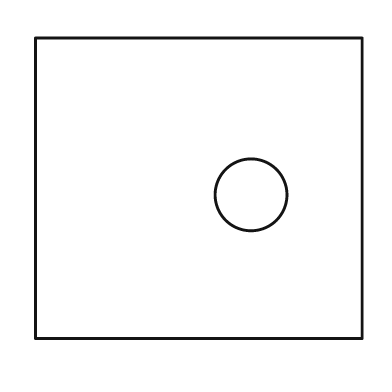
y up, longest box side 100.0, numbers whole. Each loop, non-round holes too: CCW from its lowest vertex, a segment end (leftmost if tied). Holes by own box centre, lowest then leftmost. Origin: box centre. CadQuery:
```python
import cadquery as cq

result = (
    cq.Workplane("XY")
    .moveTo(-50.0, -46.0)
    .lineTo(50.0, -46.0)
    .lineTo(50.0, 46.0)
    .lineTo(-50.0, 46.0)
    .close()
    .moveTo(16.0, -2.0)
    .circle(11.0)
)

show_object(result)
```